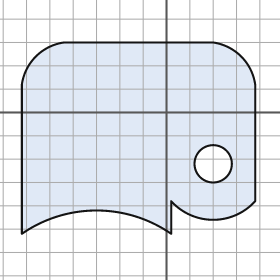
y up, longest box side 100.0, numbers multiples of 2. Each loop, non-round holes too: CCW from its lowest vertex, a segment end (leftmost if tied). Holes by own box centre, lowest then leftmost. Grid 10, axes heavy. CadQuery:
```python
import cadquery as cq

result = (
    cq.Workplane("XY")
    .moveTo(-62.0, -52.0)
    .threePointArc((-30.0, -42.0), (2.0, -52.0))
    .lineTo(2.0, -38.0)
    .threePointArc((20.0, -46.0), (38.0, -38.0))
    .lineTo(38.0, 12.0)
    .threePointArc((32.0, 24.0), (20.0, 30.0))
    .lineTo(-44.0, 30.0)
    .threePointArc((-56.0, 24.0), (-62.0, 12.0))
    .close()
    .moveTo(20.0, -22.0)
    .circle(8.0)
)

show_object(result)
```